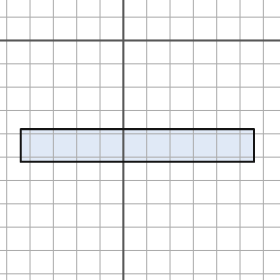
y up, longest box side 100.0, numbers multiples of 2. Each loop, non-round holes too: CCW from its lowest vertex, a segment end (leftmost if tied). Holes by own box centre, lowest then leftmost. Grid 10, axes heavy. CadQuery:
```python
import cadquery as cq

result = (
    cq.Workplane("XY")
    .moveTo(-44.0, -52.0)
    .lineTo(56.0, -52.0)
    .lineTo(56.0, -38.0)
    .lineTo(-44.0, -38.0)
    .close()
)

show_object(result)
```